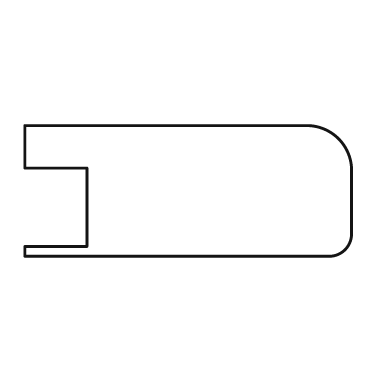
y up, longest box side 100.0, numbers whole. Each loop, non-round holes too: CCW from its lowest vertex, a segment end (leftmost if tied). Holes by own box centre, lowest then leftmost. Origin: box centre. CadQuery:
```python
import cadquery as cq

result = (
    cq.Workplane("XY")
    .moveTo(-50.0, -20.0)
    .lineTo(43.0, -20.0)
    .threePointArc((48.0, -18.0), (50.0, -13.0))
    .lineTo(50.0, 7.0)
    .threePointArc((46.0, 16.0), (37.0, 20.0))
    .lineTo(-50.0, 20.0)
    .lineTo(-50.0, 7.0)
    .lineTo(-31.0, 7.0)
    .lineTo(-31.0, -17.0)
    .lineTo(-50.0, -17.0)
    .close()
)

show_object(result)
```